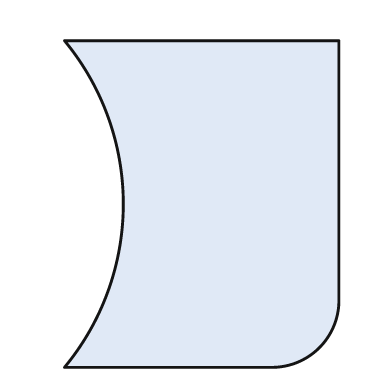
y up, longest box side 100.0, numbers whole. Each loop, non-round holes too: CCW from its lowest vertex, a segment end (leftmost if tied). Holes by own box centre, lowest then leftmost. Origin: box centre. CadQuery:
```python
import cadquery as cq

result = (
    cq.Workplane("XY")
    .moveTo(-42.0, -50.0)
    .lineTo(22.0, -50.0)
    .threePointArc((36.0, -44.0), (42.0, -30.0))
    .lineTo(42.0, 50.0)
    .lineTo(-42.0, 50.0)
    .threePointArc((-24.0, 0.0), (-42.0, -50.0))
    .close()
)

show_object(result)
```